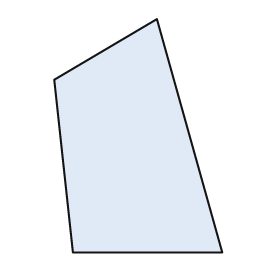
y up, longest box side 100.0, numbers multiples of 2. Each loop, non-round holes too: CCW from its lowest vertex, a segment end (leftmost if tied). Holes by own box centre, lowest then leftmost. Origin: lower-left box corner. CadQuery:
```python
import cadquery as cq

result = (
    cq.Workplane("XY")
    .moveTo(8.0, 0.0)
    .lineTo(72.0, 0.0)
    .lineTo(44.0, 100.0)
    .lineTo(0.0, 74.0)
    .close()
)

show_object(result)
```